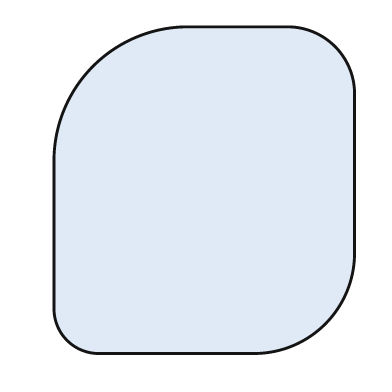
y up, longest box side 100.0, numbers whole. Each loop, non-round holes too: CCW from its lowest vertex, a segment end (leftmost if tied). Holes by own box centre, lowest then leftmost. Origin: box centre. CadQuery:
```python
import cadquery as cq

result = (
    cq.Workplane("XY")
    .moveTo(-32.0, -50.0)
    .lineTo(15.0, -50.0)
    .threePointArc((37.0, -41.0), (46.0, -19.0))
    .lineTo(46.0, 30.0)
    .threePointArc((40.0, 44.0), (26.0, 50.0))
    .lineTo(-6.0, 50.0)
    .threePointArc((-34.0, 38.0), (-46.0, 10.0))
    .lineTo(-46.0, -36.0)
    .threePointArc((-42.0, -46.0), (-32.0, -50.0))
    .close()
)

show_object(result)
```